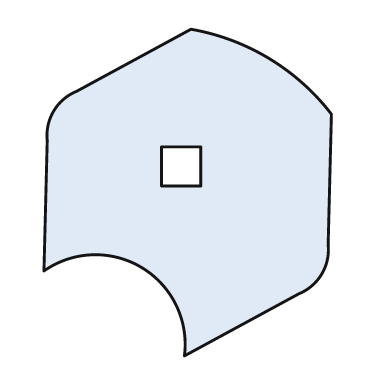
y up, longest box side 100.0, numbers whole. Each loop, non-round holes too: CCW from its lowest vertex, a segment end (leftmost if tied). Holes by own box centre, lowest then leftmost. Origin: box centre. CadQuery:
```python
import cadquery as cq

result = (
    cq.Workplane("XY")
    .moveTo(-1.0, -50.0)
    .lineTo(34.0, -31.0)
    .threePointArc((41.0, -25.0), (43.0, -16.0))
    .lineTo(44.0, 24.0)
    .threePointArc((25.0, 41.0), (1.0, 50.0))
    .lineTo(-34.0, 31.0)
    .threePointArc((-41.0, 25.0), (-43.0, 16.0))
    .lineTo(-44.0, -24.0)
    .threePointArc((-14.0, -23.0), (-1.0, -50.0))
    .close()
    .moveTo(-8.0, 2.0)
    .lineTo(4.0, 2.0)
    .lineTo(4.0, 14.0)
    .lineTo(-8.0, 14.0)
    .close()
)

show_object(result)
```